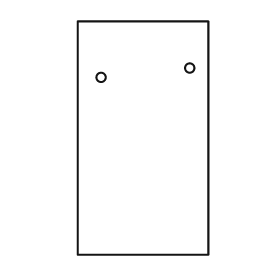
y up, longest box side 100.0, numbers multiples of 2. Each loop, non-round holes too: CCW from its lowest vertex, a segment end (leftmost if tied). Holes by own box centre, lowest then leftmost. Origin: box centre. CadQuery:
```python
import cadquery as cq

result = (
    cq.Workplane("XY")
    .moveTo(-28.0, -50.0)
    .lineTo(28.0, -50.0)
    .lineTo(28.0, 50.0)
    .lineTo(-28.0, 50.0)
    .close()
    .moveTo(-18.0, 26.0)
    .circle(2.0)
    .moveTo(20.0, 30.0)
    .circle(2.0)
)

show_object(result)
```